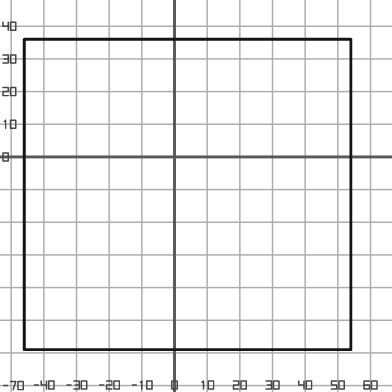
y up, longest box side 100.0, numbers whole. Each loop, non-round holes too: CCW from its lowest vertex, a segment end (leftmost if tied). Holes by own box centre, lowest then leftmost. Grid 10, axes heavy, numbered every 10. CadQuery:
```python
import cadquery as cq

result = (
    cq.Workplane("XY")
    .moveTo(-46.0, -59.0)
    .lineTo(54.0, -59.0)
    .lineTo(54.0, 36.0)
    .lineTo(-46.0, 36.0)
    .close()
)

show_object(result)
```